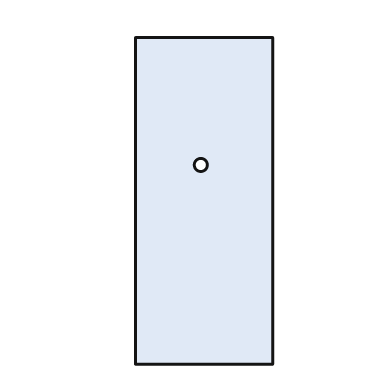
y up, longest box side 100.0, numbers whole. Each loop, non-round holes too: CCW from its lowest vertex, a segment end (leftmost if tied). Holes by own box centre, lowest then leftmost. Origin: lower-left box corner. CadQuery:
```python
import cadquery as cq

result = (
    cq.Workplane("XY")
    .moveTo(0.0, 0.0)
    .lineTo(42.0, 0.0)
    .lineTo(42.0, 100.0)
    .lineTo(0.0, 100.0)
    .close()
    .moveTo(20.0, 61.0)
    .circle(2.0)
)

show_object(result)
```